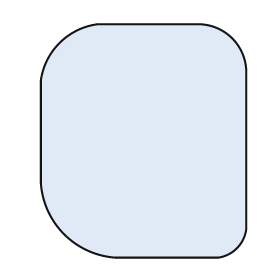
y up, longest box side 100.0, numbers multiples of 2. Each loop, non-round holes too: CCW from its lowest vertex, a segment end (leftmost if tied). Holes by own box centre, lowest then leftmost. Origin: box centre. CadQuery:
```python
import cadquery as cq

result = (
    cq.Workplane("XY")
    .moveTo(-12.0, -50.0)
    .lineTo(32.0, -50.0)
    .threePointArc((40.0, -46.0), (44.0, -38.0))
    .lineTo(44.0, 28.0)
    .threePointArc((38.0, 44.0), (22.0, 50.0))
    .lineTo(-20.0, 50.0)
    .threePointArc((-36.0, 42.0), (-44.0, 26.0))
    .lineTo(-44.0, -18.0)
    .threePointArc((-34.0, -40.0), (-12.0, -50.0))
    .close()
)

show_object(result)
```